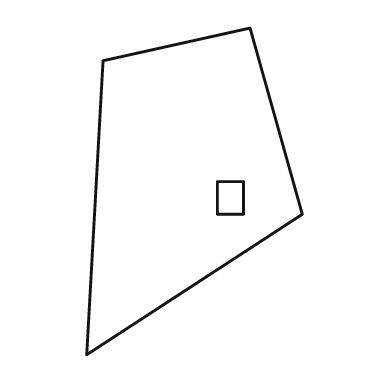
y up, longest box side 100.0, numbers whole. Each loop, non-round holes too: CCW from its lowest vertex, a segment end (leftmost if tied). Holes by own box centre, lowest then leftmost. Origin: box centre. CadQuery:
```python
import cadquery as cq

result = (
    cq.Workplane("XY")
    .moveTo(-33.0, -50.0)
    .lineTo(33.0, -7.0)
    .lineTo(17.0, 50.0)
    .lineTo(-28.0, 40.0)
    .close()
    .moveTo(7.0, -7.0)
    .lineTo(15.0, -7.0)
    .lineTo(15.0, 3.0)
    .lineTo(7.0, 3.0)
    .close()
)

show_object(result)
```